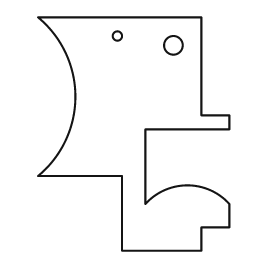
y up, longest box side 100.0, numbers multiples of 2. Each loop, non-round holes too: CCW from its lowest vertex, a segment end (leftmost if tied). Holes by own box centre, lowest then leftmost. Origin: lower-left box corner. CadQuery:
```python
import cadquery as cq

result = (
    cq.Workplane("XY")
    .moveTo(36.0, 0.0)
    .lineTo(70.0, 0.0)
    .lineTo(70.0, 10.0)
    .lineTo(82.0, 10.0)
    .lineTo(82.0, 20.0)
    .threePointArc((64.0, 28.0), (46.0, 20.0))
    .lineTo(46.0, 52.0)
    .lineTo(82.0, 52.0)
    .lineTo(82.0, 58.0)
    .lineTo(70.0, 58.0)
    .lineTo(70.0, 100.0)
    .lineTo(0.0, 100.0)
    .threePointArc((16.0, 66.0), (0.0, 32.0))
    .lineTo(36.0, 32.0)
    .close()
    .moveTo(58.0, 88.0)
    .circle(4.0)
    .moveTo(34.0, 92.0)
    .circle(2.0)
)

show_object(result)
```